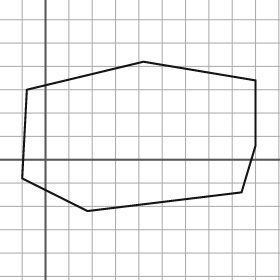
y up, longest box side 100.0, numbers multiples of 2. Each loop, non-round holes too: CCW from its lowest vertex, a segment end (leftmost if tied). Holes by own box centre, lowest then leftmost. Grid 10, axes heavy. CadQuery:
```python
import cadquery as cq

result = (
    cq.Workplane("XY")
    .moveTo(18.0, -22.0)
    .lineTo(84.0, -14.0)
    .lineTo(90.0, 6.0)
    .lineTo(90.0, 34.0)
    .lineTo(42.0, 42.0)
    .lineTo(-8.0, 30.0)
    .lineTo(-10.0, -8.0)
    .close()
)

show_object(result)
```